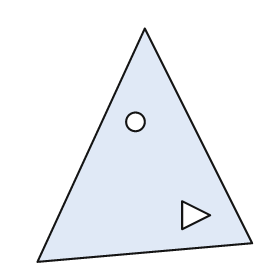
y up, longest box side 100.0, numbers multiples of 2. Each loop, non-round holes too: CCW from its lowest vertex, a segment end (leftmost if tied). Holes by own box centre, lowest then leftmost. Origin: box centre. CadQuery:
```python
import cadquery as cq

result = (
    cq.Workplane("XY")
    .moveTo(-46.0, -50.0)
    .lineTo(46.0, -42.0)
    .lineTo(0.0, 50.0)
    .close()
    .moveTo(16.0, -36.0)
    .lineTo(28.0, -30.0)
    .lineTo(16.0, -24.0)
    .close()
    .moveTo(-4.0, 10.0)
    .circle(4.0)
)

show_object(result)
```